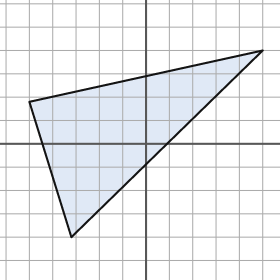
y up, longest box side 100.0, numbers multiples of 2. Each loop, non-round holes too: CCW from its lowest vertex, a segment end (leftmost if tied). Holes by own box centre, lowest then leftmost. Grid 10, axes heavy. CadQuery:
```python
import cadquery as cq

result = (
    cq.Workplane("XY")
    .moveTo(-32.0, -40.0)
    .lineTo(50.0, 40.0)
    .lineTo(-50.0, 18.0)
    .close()
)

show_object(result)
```